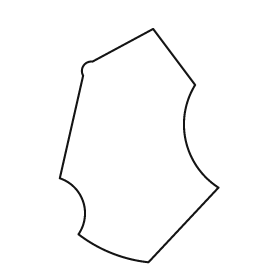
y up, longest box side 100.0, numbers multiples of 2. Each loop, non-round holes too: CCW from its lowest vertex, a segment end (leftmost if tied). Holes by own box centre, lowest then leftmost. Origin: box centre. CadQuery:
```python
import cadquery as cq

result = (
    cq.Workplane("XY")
    .moveTo(4.0, -50.0)
    .lineTo(34.0, -18.0)
    .threePointArc((20.0, 2.0), (24.0, 26.0))
    .lineTo(6.0, 50.0)
    .lineTo(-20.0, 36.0)
    .threePointArc((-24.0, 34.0), (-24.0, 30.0))
    .lineTo(-34.0, -14.0)
    .threePointArc((-24.0, -24.0), (-26.0, -38.0))
    .threePointArc((-12.0, -46.0), (4.0, -50.0))
    .close()
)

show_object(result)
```